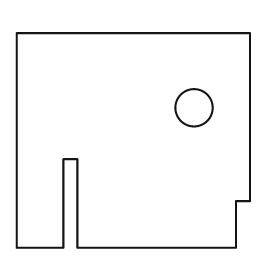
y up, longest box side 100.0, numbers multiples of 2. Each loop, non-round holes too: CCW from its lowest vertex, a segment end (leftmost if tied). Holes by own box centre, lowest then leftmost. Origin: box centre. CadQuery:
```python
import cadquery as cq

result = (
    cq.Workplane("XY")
    .moveTo(-50.0, -46.0)
    .lineTo(-30.0, -46.0)
    .lineTo(-30.0, -8.0)
    .lineTo(-24.0, -8.0)
    .lineTo(-24.0, -46.0)
    .lineTo(44.0, -46.0)
    .lineTo(44.0, -26.0)
    .lineTo(50.0, -26.0)
    .lineTo(50.0, 46.0)
    .lineTo(-50.0, 46.0)
    .close()
    .moveTo(26.0, 14.0)
    .circle(8.0)
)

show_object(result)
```